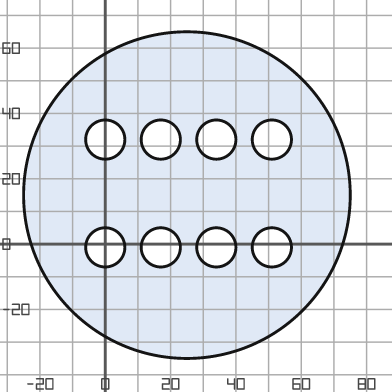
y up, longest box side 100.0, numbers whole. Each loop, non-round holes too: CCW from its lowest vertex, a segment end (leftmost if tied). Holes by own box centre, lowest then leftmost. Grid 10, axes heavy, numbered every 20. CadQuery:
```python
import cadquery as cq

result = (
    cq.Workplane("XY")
    .moveTo(25.0, 15.0)
    .circle(50.0)
    .moveTo(0.0, -1.0)
    .circle(6.0)
    .moveTo(17.0, -1.0)
    .circle(6.0)
    .moveTo(34.0, -1.0)
    .circle(6.0)
    .moveTo(51.0, -1.0)
    .circle(6.0)
    .moveTo(0.0, 32.0)
    .circle(6.0)
    .moveTo(17.0, 32.0)
    .circle(6.0)
    .moveTo(34.0, 32.0)
    .circle(6.0)
    .moveTo(51.0, 32.0)
    .circle(6.0)
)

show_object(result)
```